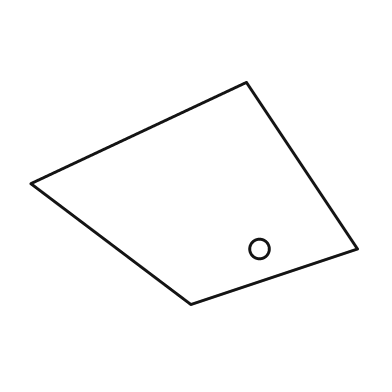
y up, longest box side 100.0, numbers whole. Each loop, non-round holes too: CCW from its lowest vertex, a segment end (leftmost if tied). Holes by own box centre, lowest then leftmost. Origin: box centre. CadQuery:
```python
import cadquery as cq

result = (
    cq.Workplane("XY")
    .moveTo(-1.0, -34.0)
    .lineTo(50.0, -17.0)
    .lineTo(16.0, 34.0)
    .lineTo(-50.0, 3.0)
    .close()
    .moveTo(20.0, -17.0)
    .circle(3.0)
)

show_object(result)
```